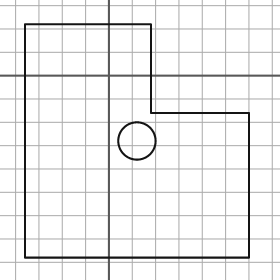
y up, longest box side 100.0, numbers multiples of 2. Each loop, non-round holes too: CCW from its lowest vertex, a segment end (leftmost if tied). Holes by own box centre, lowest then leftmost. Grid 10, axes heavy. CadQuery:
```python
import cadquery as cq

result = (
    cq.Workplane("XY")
    .moveTo(-36.0, -78.0)
    .lineTo(60.0, -78.0)
    .lineTo(60.0, -16.0)
    .lineTo(18.0, -16.0)
    .lineTo(18.0, 22.0)
    .lineTo(-36.0, 22.0)
    .close()
    .moveTo(12.0, -28.0)
    .circle(8.0)
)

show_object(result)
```